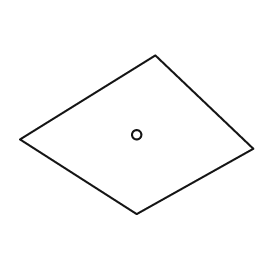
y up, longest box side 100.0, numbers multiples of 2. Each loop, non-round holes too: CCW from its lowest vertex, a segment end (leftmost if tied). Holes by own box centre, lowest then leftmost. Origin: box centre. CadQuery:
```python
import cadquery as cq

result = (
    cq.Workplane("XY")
    .moveTo(0.0, -34.0)
    .lineTo(50.0, -6.0)
    .lineTo(8.0, 34.0)
    .lineTo(-50.0, -2.0)
    .close()
    .moveTo(0.0, 0.0)
    .circle(2.0)
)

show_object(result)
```